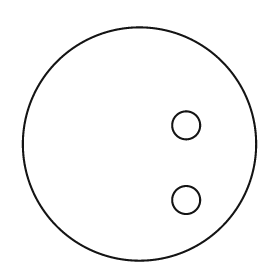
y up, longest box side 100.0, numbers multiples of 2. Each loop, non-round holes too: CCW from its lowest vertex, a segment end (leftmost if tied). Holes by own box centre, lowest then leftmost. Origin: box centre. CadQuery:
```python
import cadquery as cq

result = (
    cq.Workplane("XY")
    .moveTo(0.0, 0.0)
    .circle(50.0)
    .moveTo(20.0, -24.0)
    .circle(6.0)
    .moveTo(20.0, 8.0)
    .circle(6.0)
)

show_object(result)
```